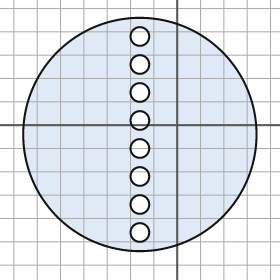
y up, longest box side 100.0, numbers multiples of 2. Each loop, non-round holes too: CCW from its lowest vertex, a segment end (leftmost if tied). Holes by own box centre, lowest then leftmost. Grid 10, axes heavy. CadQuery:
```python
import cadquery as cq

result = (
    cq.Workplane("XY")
    .moveTo(-16.0, -4.0)
    .circle(50.0)
    .moveTo(-16.0, -46.0)
    .circle(4.0)
    .moveTo(-16.0, -34.0)
    .circle(4.0)
    .moveTo(-16.0, -22.0)
    .circle(4.0)
    .moveTo(-16.0, -10.0)
    .circle(4.0)
    .moveTo(-16.0, 2.0)
    .circle(4.0)
    .moveTo(-16.0, 14.0)
    .circle(4.0)
    .moveTo(-16.0, 26.0)
    .circle(4.0)
    .moveTo(-16.0, 38.0)
    .circle(4.0)
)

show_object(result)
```